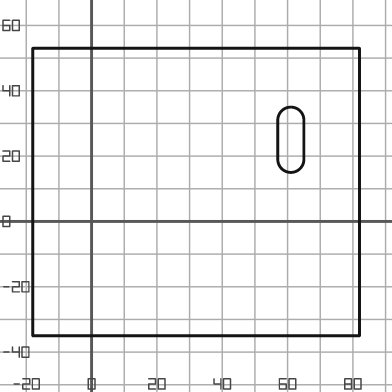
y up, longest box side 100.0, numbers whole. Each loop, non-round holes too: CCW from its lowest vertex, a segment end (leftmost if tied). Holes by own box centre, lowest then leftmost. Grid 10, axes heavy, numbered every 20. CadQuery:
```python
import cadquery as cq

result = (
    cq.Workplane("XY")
    .moveTo(-18.0, -35.0)
    .lineTo(82.0, -35.0)
    .lineTo(82.0, 53.0)
    .lineTo(-18.0, 53.0)
    .close()
    .moveTo(57.0, 19.0)
    .threePointArc((61.0, 15.0), (65.0, 19.0))
    .lineTo(65.0, 31.0)
    .threePointArc((61.0, 35.0), (57.0, 31.0))
    .close()
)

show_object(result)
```